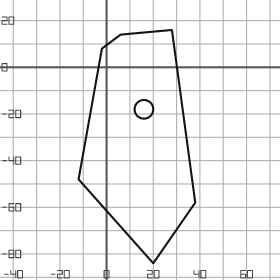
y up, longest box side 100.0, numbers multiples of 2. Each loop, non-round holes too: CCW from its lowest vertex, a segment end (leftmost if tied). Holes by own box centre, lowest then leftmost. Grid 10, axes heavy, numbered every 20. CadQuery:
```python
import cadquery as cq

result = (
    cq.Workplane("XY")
    .moveTo(20.0, -84.0)
    .lineTo(38.0, -58.0)
    .lineTo(28.0, 16.0)
    .lineTo(6.0, 14.0)
    .lineTo(-2.0, 8.0)
    .lineTo(-12.0, -48.0)
    .close()
    .moveTo(16.0, -18.0)
    .circle(4.0)
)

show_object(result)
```